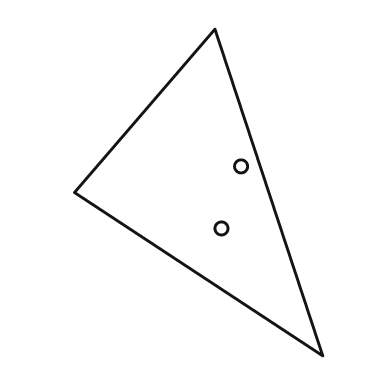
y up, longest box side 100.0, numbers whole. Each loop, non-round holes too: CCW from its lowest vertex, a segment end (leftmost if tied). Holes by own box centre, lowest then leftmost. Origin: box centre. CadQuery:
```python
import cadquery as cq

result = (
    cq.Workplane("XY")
    .moveTo(38.0, -50.0)
    .lineTo(5.0, 50.0)
    .lineTo(-38.0, 0.0)
    .close()
    .moveTo(7.0, -11.0)
    .circle(2.0)
    .moveTo(13.0, 8.0)
    .circle(2.0)
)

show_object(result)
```